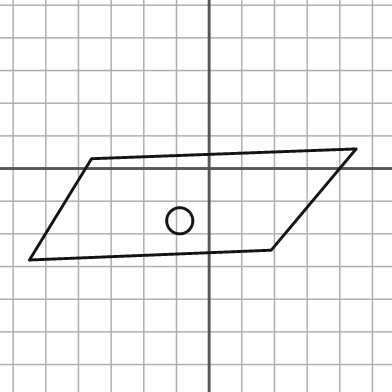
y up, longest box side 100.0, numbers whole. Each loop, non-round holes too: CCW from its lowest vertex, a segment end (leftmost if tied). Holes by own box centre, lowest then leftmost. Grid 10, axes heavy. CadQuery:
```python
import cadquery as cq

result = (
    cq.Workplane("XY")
    .moveTo(-55.0, -28.0)
    .lineTo(19.0, -25.0)
    .lineTo(45.0, 6.0)
    .lineTo(-36.0, 3.0)
    .close()
    .moveTo(-9.0, -16.0)
    .circle(4.0)
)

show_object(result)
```